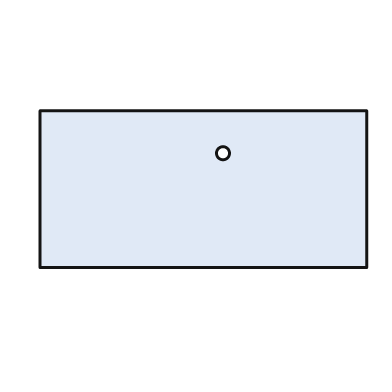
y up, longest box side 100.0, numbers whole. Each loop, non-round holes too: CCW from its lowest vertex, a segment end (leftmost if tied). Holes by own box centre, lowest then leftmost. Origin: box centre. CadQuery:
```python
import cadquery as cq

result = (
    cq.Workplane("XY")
    .moveTo(-50.0, -24.0)
    .lineTo(50.0, -24.0)
    .lineTo(50.0, 24.0)
    .lineTo(-50.0, 24.0)
    .close()
    .moveTo(6.0, 11.0)
    .circle(2.0)
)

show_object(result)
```